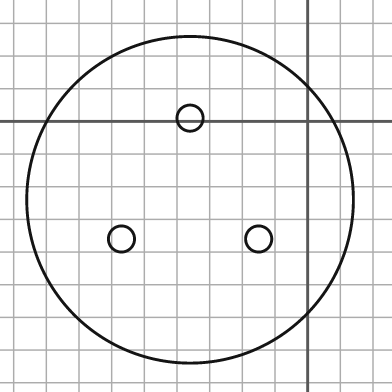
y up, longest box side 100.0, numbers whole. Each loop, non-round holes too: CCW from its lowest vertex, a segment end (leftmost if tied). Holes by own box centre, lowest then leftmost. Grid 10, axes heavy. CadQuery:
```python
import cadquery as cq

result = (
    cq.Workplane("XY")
    .moveTo(-36.0, -24.0)
    .circle(50.0)
    .moveTo(-57.0, -36.0)
    .circle(4.0)
    .moveTo(-15.0, -36.0)
    .circle(4.0)
    .moveTo(-36.0, 1.0)
    .circle(4.0)
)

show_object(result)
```